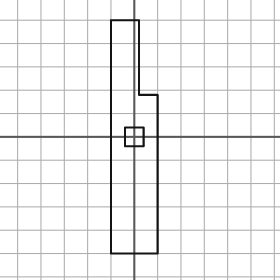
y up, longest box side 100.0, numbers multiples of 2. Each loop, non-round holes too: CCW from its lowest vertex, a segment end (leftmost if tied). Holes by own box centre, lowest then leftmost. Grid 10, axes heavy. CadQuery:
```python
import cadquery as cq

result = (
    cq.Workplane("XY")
    .moveTo(-10.0, -50.0)
    .lineTo(10.0, -50.0)
    .lineTo(10.0, 18.0)
    .lineTo(2.0, 18.0)
    .lineTo(2.0, 50.0)
    .lineTo(-10.0, 50.0)
    .close()
    .moveTo(-4.0, -4.0)
    .lineTo(4.0, -4.0)
    .lineTo(4.0, 4.0)
    .lineTo(-4.0, 4.0)
    .close()
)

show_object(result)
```